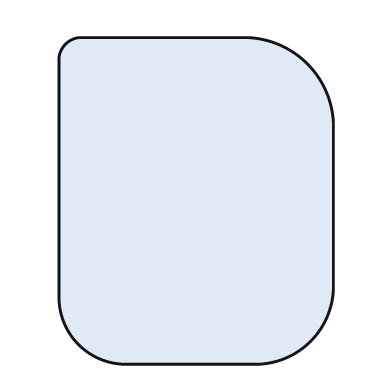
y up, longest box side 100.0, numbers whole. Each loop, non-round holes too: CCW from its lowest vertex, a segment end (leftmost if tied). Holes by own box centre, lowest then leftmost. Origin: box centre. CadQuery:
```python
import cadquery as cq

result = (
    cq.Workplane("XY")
    .moveTo(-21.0, -50.0)
    .lineTo(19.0, -50.0)
    .threePointArc((35.0, -43.0), (42.0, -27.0))
    .lineTo(42.0, 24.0)
    .threePointArc((34.0, 42.0), (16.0, 50.0))
    .lineTo(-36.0, 50.0)
    .threePointArc((-40.0, 48.0), (-42.0, 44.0))
    .lineTo(-42.0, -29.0)
    .threePointArc((-36.0, -44.0), (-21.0, -50.0))
    .close()
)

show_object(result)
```